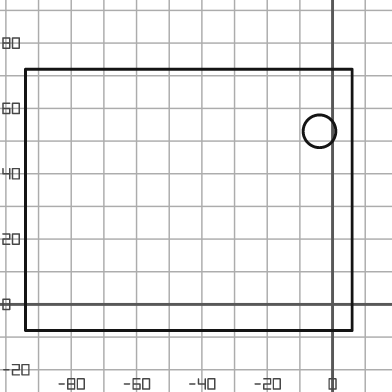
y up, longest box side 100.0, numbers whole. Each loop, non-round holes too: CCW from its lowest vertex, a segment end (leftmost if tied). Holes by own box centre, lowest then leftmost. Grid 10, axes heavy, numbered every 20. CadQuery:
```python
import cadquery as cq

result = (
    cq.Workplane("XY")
    .moveTo(-94.0, -8.0)
    .lineTo(6.0, -8.0)
    .lineTo(6.0, 72.0)
    .lineTo(-94.0, 72.0)
    .close()
    .moveTo(-4.0, 53.0)
    .circle(5.0)
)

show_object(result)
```